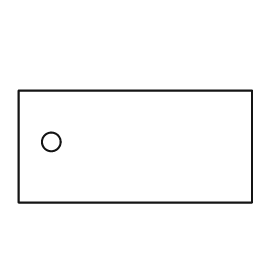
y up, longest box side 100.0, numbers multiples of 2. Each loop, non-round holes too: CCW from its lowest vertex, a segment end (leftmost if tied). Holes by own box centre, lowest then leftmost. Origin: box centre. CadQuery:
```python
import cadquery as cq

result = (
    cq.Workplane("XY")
    .moveTo(-50.0, -24.0)
    .lineTo(50.0, -24.0)
    .lineTo(50.0, 24.0)
    .lineTo(-50.0, 24.0)
    .close()
    .moveTo(-36.0, 2.0)
    .circle(4.0)
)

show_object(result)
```